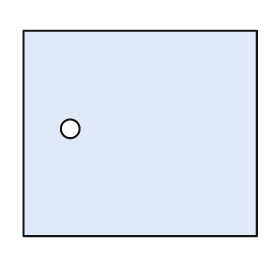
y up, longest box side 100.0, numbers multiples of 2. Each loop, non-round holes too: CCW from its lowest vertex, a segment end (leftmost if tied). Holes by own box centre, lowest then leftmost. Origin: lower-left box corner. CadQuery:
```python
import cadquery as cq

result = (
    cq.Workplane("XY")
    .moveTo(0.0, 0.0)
    .lineTo(100.0, 0.0)
    .lineTo(100.0, 88.0)
    .lineTo(0.0, 88.0)
    .close()
    .moveTo(20.0, 46.0)
    .circle(4.0)
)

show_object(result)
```